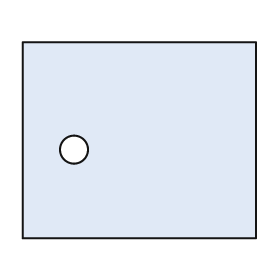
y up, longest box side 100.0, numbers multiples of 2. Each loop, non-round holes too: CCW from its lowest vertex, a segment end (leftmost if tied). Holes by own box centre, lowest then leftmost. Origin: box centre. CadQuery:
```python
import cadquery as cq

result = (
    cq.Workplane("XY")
    .moveTo(-50.0, -42.0)
    .lineTo(50.0, -42.0)
    .lineTo(50.0, 42.0)
    .lineTo(-50.0, 42.0)
    .close()
    .moveTo(-28.0, -4.0)
    .circle(6.0)
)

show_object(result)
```